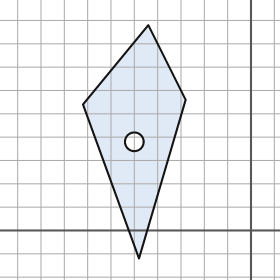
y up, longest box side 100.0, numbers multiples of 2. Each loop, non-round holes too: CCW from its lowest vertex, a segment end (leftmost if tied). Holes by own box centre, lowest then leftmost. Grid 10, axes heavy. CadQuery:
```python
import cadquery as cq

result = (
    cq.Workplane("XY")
    .moveTo(-48.0, -12.0)
    .lineTo(-28.0, 56.0)
    .lineTo(-44.0, 88.0)
    .lineTo(-72.0, 54.0)
    .close()
    .moveTo(-50.0, 38.0)
    .circle(4.0)
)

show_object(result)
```